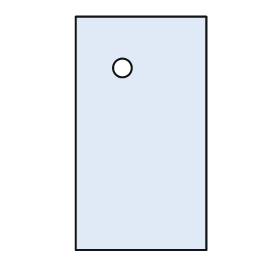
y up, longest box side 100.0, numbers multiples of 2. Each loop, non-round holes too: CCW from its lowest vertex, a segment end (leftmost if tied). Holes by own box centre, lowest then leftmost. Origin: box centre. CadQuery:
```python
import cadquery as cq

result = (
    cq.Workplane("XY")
    .moveTo(-28.0, -50.0)
    .lineTo(28.0, -50.0)
    .lineTo(28.0, 50.0)
    .lineTo(-28.0, 50.0)
    .close()
    .moveTo(-8.0, 28.0)
    .circle(4.0)
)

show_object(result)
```